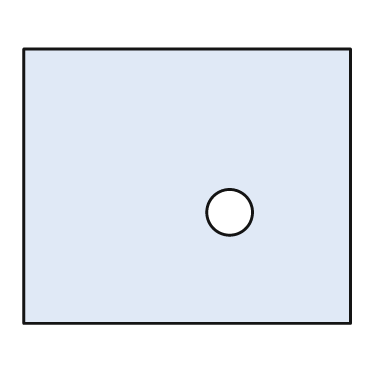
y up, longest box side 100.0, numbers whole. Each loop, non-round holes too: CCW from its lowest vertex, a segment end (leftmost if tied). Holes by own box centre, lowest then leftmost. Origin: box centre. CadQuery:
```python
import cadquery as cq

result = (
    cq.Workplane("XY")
    .moveTo(-50.0, -42.0)
    .lineTo(50.0, -42.0)
    .lineTo(50.0, 42.0)
    .lineTo(-50.0, 42.0)
    .close()
    .moveTo(13.0, -8.0)
    .circle(7.0)
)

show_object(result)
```